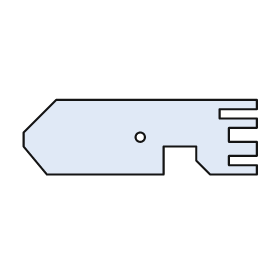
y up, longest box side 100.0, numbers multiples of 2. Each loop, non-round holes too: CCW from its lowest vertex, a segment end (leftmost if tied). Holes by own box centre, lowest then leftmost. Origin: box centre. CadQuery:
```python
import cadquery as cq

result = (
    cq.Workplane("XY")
    .moveTo(-40.0, -16.0)
    .lineTo(10.0, -16.0)
    .lineTo(10.0, -4.0)
    .lineTo(24.0, -4.0)
    .lineTo(24.0, -10.0)
    .lineTo(30.0, -16.0)
    .lineTo(50.0, -16.0)
    .lineTo(50.0, -12.0)
    .lineTo(38.0, -12.0)
    .lineTo(38.0, -8.0)
    .lineTo(50.0, -8.0)
    .lineTo(50.0, -2.0)
    .lineTo(38.0, -2.0)
    .lineTo(38.0, 4.0)
    .lineTo(50.0, 4.0)
    .lineTo(50.0, 8.0)
    .lineTo(34.0, 8.0)
    .lineTo(34.0, 12.0)
    .lineTo(50.0, 12.0)
    .lineTo(50.0, 16.0)
    .lineTo(-36.0, 16.0)
    .lineTo(-50.0, 2.0)
    .lineTo(-50.0, -4.0)
    .close()
    .moveTo(0.0, 0.0)
    .circle(2.0)
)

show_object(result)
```